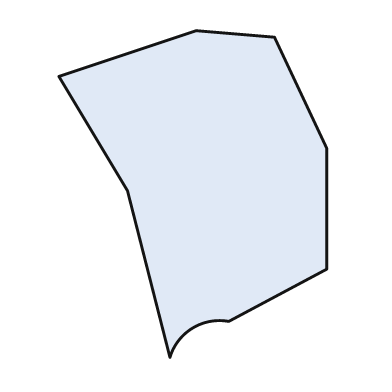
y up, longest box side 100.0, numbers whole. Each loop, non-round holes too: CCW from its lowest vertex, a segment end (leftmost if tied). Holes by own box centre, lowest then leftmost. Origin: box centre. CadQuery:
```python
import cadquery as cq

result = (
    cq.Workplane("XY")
    .moveTo(-7.0, -50.0)
    .threePointArc((0.0, -41.0), (11.0, -39.0))
    .lineTo(41.0, -23.0)
    .lineTo(41.0, 14.0)
    .lineTo(25.0, 48.0)
    .lineTo(1.0, 50.0)
    .lineTo(-41.0, 36.0)
    .lineTo(-20.0, 1.0)
    .close()
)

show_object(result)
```